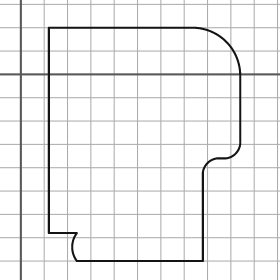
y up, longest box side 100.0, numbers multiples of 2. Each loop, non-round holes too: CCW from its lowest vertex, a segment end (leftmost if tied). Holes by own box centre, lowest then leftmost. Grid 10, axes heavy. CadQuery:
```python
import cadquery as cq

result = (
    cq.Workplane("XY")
    .moveTo(24.0, -80.0)
    .lineTo(78.0, -80.0)
    .lineTo(78.0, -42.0)
    .threePointArc((80.0, -38.0), (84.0, -36.0))
    .lineTo(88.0, -36.0)
    .threePointArc((92.0, -34.0), (94.0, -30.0))
    .lineTo(94.0, 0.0)
    .threePointArc((88.0, 14.0), (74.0, 20.0))
    .lineTo(12.0, 20.0)
    .lineTo(12.0, -68.0)
    .lineTo(24.0, -68.0)
    .threePointArc((22.0, -74.0), (24.0, -80.0))
    .close()
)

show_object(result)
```